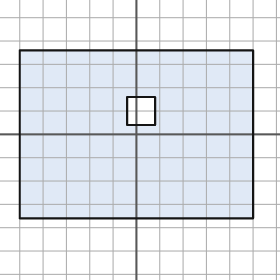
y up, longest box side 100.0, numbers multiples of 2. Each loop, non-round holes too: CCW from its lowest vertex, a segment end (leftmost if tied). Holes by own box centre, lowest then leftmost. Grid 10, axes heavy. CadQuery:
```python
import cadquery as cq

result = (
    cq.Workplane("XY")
    .moveTo(-50.0, -36.0)
    .lineTo(50.0, -36.0)
    .lineTo(50.0, 36.0)
    .lineTo(-50.0, 36.0)
    .close()
    .moveTo(-4.0, 4.0)
    .lineTo(8.0, 4.0)
    .lineTo(8.0, 16.0)
    .lineTo(-4.0, 16.0)
    .close()
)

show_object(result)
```